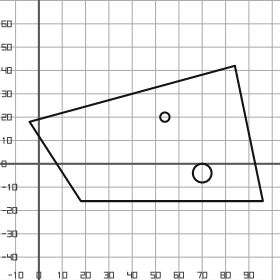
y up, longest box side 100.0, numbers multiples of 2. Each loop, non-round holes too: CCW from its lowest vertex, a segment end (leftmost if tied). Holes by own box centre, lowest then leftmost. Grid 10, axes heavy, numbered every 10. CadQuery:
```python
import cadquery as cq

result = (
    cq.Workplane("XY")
    .moveTo(18.0, -16.0)
    .lineTo(96.0, -16.0)
    .lineTo(84.0, 42.0)
    .lineTo(-4.0, 18.0)
    .close()
    .moveTo(70.0, -4.0)
    .circle(4.0)
    .moveTo(54.0, 20.0)
    .circle(2.0)
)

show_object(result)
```